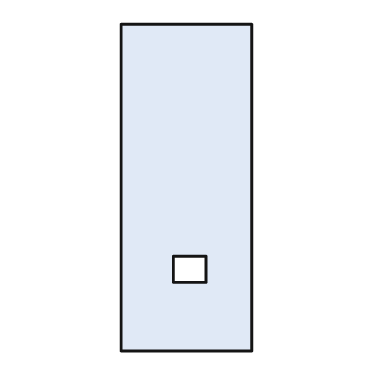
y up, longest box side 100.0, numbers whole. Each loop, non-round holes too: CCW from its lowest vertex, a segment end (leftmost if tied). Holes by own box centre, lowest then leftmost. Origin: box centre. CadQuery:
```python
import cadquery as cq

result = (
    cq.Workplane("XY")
    .moveTo(-20.0, -50.0)
    .lineTo(20.0, -50.0)
    .lineTo(20.0, 50.0)
    .lineTo(-20.0, 50.0)
    .close()
    .moveTo(-4.0, -29.0)
    .lineTo(6.0, -29.0)
    .lineTo(6.0, -21.0)
    .lineTo(-4.0, -21.0)
    .close()
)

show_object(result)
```